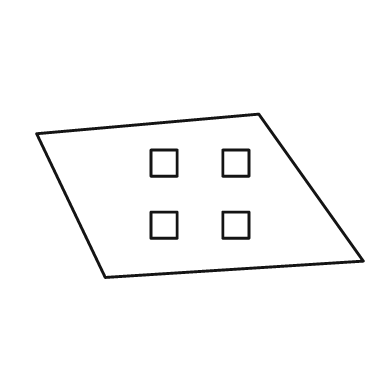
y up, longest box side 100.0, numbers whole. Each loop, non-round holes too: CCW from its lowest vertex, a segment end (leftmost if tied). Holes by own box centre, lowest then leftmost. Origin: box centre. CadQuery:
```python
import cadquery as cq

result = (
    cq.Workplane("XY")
    .moveTo(-29.0, -25.0)
    .lineTo(50.0, -20.0)
    .lineTo(18.0, 25.0)
    .lineTo(-50.0, 19.0)
    .close()
    .moveTo(-15.0, -13.0)
    .lineTo(-7.0, -13.0)
    .lineTo(-7.0, -5.0)
    .lineTo(-15.0, -5.0)
    .close()
    .moveTo(7.0, -13.0)
    .lineTo(15.0, -13.0)
    .lineTo(15.0, -5.0)
    .lineTo(7.0, -5.0)
    .close()
    .moveTo(-15.0, 6.0)
    .lineTo(-7.0, 6.0)
    .lineTo(-7.0, 14.0)
    .lineTo(-15.0, 14.0)
    .close()
    .moveTo(7.0, 6.0)
    .lineTo(15.0, 6.0)
    .lineTo(15.0, 14.0)
    .lineTo(7.0, 14.0)
    .close()
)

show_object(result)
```